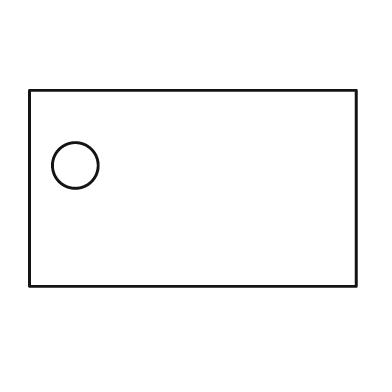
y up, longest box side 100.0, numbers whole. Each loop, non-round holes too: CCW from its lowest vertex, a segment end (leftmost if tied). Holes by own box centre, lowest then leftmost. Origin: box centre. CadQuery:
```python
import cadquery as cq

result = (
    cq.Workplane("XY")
    .moveTo(-50.0, -30.0)
    .lineTo(50.0, -30.0)
    .lineTo(50.0, 30.0)
    .lineTo(-50.0, 30.0)
    .close()
    .moveTo(-36.0, 7.0)
    .circle(7.0)
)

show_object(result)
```